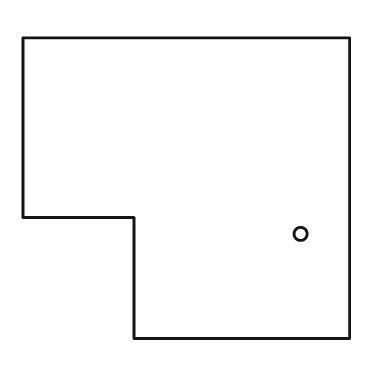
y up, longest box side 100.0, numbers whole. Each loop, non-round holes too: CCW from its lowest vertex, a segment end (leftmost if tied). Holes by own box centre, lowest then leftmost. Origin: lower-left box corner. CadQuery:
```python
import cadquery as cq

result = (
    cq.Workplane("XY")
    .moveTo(34.0, 0.0)
    .lineTo(100.0, 0.0)
    .lineTo(100.0, 92.0)
    .lineTo(0.0, 92.0)
    .lineTo(0.0, 37.0)
    .lineTo(34.0, 37.0)
    .close()
    .moveTo(85.0, 32.0)
    .circle(2.0)
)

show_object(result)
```